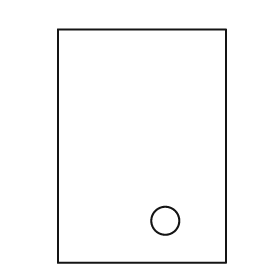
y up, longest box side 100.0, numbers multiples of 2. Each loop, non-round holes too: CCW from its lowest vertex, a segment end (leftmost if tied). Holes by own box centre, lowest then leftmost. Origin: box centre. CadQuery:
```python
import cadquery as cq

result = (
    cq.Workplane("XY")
    .moveTo(-36.0, -50.0)
    .lineTo(36.0, -50.0)
    .lineTo(36.0, 50.0)
    .lineTo(-36.0, 50.0)
    .close()
    .moveTo(10.0, -32.0)
    .circle(6.0)
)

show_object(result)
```